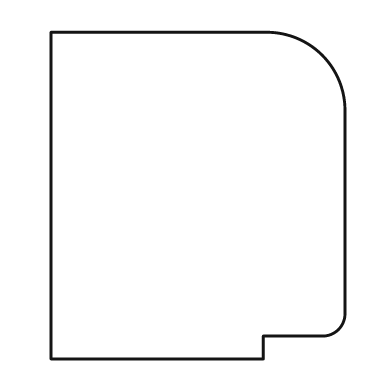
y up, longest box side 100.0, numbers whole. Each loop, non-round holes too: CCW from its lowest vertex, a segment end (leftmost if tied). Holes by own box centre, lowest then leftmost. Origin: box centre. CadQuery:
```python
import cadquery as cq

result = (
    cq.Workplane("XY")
    .moveTo(-45.0, -50.0)
    .lineTo(20.0, -50.0)
    .lineTo(20.0, -43.0)
    .lineTo(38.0, -43.0)
    .threePointArc((43.0, -41.0), (45.0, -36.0))
    .lineTo(45.0, 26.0)
    .threePointArc((38.0, 43.0), (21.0, 50.0))
    .lineTo(-45.0, 50.0)
    .close()
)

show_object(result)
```